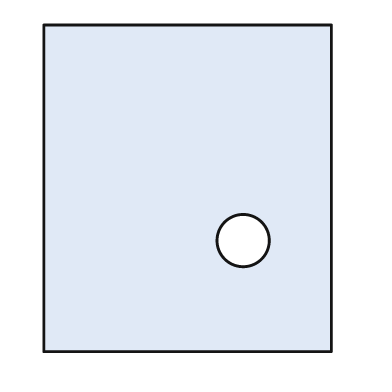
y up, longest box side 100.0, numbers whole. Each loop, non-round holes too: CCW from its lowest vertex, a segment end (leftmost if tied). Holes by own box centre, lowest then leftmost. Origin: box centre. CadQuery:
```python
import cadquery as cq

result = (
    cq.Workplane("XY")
    .moveTo(-44.0, -50.0)
    .lineTo(44.0, -50.0)
    .lineTo(44.0, 50.0)
    .lineTo(-44.0, 50.0)
    .close()
    .moveTo(17.0, -16.0)
    .circle(8.0)
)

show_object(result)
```